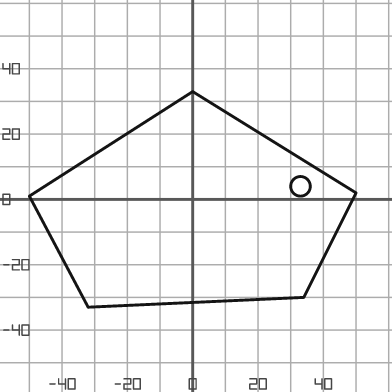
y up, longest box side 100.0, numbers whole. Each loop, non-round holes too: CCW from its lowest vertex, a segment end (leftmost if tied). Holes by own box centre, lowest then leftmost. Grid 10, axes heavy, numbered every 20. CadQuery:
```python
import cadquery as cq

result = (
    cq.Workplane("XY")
    .moveTo(-32.0, -33.0)
    .lineTo(34.0, -30.0)
    .lineTo(50.0, 2.0)
    .lineTo(0.0, 33.0)
    .lineTo(-50.0, 1.0)
    .close()
    .moveTo(33.0, 4.0)
    .circle(3.0)
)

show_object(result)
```